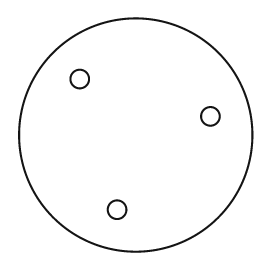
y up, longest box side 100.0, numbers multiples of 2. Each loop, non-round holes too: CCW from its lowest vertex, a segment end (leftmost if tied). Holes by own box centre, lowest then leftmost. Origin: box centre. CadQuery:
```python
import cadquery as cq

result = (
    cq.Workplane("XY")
    .moveTo(0.0, 0.0)
    .circle(50.0)
    .moveTo(-8.0, -32.0)
    .circle(4.0)
    .moveTo(32.0, 8.0)
    .circle(4.0)
    .moveTo(-24.0, 24.0)
    .circle(4.0)
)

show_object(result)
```